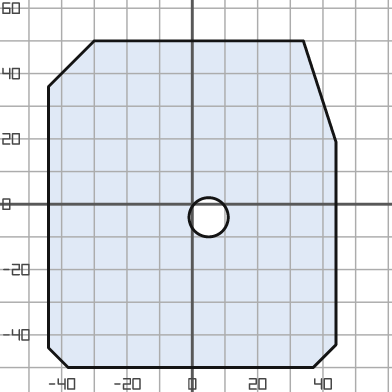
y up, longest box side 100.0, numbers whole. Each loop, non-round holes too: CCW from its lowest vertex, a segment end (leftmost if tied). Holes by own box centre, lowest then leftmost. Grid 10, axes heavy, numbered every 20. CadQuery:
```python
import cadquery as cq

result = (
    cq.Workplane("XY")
    .moveTo(-38.0, -50.0)
    .lineTo(37.0, -50.0)
    .lineTo(44.0, -43.0)
    .lineTo(44.0, 19.0)
    .lineTo(34.0, 50.0)
    .lineTo(-30.0, 50.0)
    .lineTo(-44.0, 36.0)
    .lineTo(-44.0, -44.0)
    .close()
    .moveTo(5.0, -4.0)
    .circle(6.0)
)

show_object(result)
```